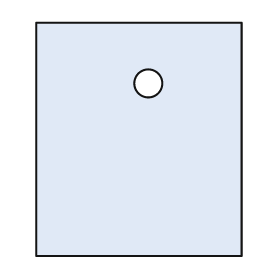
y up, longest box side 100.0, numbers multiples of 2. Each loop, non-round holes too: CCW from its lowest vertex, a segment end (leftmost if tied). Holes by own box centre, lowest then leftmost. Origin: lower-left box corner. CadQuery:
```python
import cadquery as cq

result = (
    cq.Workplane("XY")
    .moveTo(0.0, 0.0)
    .lineTo(88.0, 0.0)
    .lineTo(88.0, 100.0)
    .lineTo(0.0, 100.0)
    .close()
    .moveTo(48.0, 74.0)
    .circle(6.0)
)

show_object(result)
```